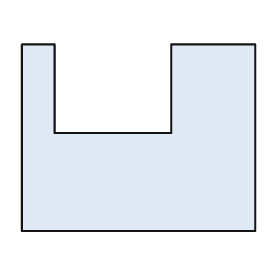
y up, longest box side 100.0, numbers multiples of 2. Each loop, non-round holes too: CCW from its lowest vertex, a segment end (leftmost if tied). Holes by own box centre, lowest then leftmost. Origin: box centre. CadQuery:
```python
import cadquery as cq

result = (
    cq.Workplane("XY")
    .moveTo(-50.0, -40.0)
    .lineTo(50.0, -40.0)
    .lineTo(50.0, 40.0)
    .lineTo(14.0, 40.0)
    .lineTo(14.0, 2.0)
    .lineTo(-36.0, 2.0)
    .lineTo(-36.0, 40.0)
    .lineTo(-50.0, 40.0)
    .close()
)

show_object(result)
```